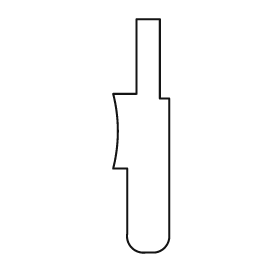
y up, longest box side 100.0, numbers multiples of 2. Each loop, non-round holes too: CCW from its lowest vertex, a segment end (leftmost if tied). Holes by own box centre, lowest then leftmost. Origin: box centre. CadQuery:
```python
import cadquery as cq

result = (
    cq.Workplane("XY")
    .moveTo(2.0, -50.0)
    .lineTo(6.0, -50.0)
    .threePointArc((10.0, -48.0), (12.0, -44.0))
    .lineTo(12.0, 16.0)
    .lineTo(8.0, 16.0)
    .lineTo(8.0, 50.0)
    .lineTo(-2.0, 50.0)
    .lineTo(-2.0, 18.0)
    .lineTo(-12.0, 18.0)
    .threePointArc((-10.0, 2.0), (-12.0, -14.0))
    .lineTo(-6.0, -14.0)
    .lineTo(-6.0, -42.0)
    .threePointArc((-4.0, -48.0), (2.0, -50.0))
    .close()
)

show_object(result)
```